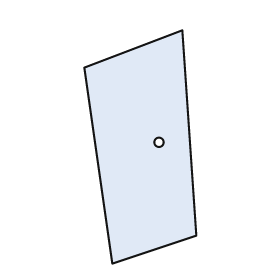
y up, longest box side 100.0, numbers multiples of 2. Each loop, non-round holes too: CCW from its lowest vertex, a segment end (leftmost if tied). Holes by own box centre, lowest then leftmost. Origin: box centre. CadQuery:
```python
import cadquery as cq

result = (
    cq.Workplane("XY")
    .moveTo(-12.0, -50.0)
    .lineTo(24.0, -38.0)
    .lineTo(18.0, 50.0)
    .lineTo(-24.0, 34.0)
    .close()
    .moveTo(8.0, 2.0)
    .circle(2.0)
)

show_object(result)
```